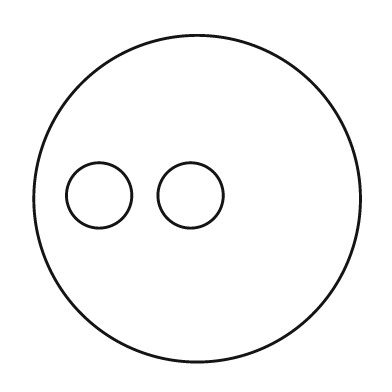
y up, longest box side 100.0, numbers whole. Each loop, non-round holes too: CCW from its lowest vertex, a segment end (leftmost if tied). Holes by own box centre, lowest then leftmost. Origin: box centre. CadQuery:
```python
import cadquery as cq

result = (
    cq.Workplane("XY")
    .moveTo(0.0, 0.0)
    .circle(50.0)
    .moveTo(-30.0, 1.0)
    .circle(10.0)
    .moveTo(-2.0, 1.0)
    .circle(10.0)
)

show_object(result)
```